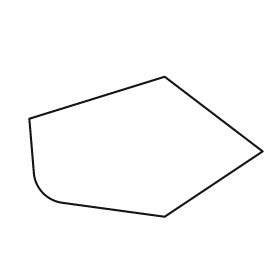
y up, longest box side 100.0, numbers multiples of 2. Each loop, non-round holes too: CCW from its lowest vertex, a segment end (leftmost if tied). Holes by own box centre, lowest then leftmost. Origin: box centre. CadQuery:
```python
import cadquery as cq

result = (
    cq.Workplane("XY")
    .moveTo(8.0, -30.0)
    .lineTo(50.0, -2.0)
    .lineTo(8.0, 30.0)
    .lineTo(-50.0, 12.0)
    .lineTo(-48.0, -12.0)
    .threePointArc((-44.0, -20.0), (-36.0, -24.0))
    .close()
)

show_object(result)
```